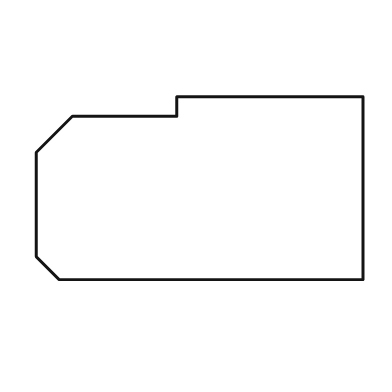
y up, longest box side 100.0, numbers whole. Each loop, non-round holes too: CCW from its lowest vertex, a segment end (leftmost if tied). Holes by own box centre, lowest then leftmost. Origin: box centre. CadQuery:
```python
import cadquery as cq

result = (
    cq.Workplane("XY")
    .moveTo(-43.0, -28.0)
    .lineTo(50.0, -28.0)
    .lineTo(50.0, 28.0)
    .lineTo(-7.0, 28.0)
    .lineTo(-7.0, 22.0)
    .lineTo(-39.0, 22.0)
    .lineTo(-50.0, 11.0)
    .lineTo(-50.0, -21.0)
    .close()
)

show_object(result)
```